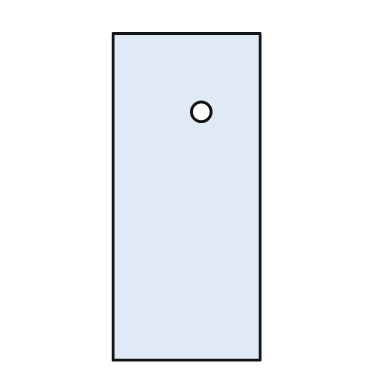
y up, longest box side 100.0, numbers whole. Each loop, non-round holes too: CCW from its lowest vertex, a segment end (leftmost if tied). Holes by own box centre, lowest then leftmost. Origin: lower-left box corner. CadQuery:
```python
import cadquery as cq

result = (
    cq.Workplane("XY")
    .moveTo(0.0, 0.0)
    .lineTo(45.0, 0.0)
    .lineTo(45.0, 100.0)
    .lineTo(0.0, 100.0)
    .close()
    .moveTo(27.0, 76.0)
    .circle(3.0)
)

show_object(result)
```